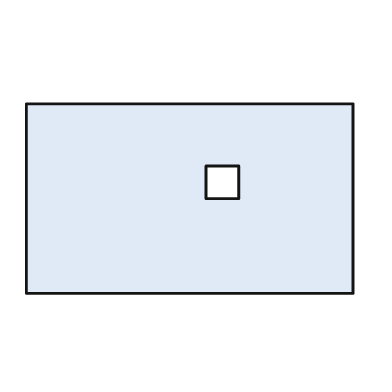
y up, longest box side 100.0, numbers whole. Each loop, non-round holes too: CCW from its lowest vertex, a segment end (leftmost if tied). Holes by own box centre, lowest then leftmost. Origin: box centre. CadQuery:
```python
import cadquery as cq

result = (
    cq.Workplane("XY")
    .moveTo(-50.0, -29.0)
    .lineTo(50.0, -29.0)
    .lineTo(50.0, 29.0)
    .lineTo(-50.0, 29.0)
    .close()
    .moveTo(5.0, 0.0)
    .lineTo(15.0, 0.0)
    .lineTo(15.0, 10.0)
    .lineTo(5.0, 10.0)
    .close()
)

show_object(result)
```